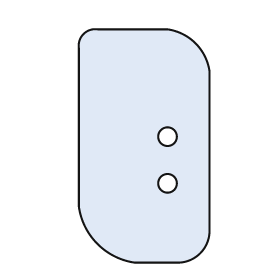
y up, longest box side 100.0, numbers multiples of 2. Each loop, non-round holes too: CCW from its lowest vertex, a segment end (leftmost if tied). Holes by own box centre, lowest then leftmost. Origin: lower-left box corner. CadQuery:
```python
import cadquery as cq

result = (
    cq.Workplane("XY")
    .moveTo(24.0, 0.0)
    .lineTo(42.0, 0.0)
    .threePointArc((52.0, 4.0), (56.0, 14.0))
    .lineTo(56.0, 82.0)
    .threePointArc((50.0, 94.0), (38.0, 100.0))
    .lineTo(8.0, 100.0)
    .threePointArc((2.0, 98.0), (0.0, 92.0))
    .lineTo(0.0, 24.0)
    .threePointArc((8.0, 8.0), (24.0, 0.0))
    .close()
    .moveTo(38.0, 34.0)
    .circle(4.0)
    .moveTo(38.0, 54.0)
    .circle(4.0)
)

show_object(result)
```